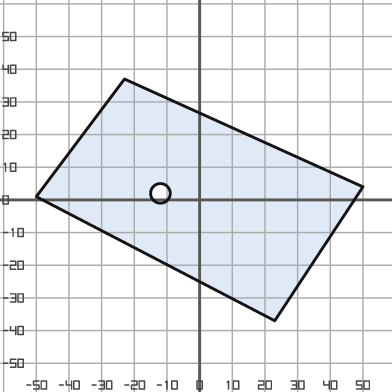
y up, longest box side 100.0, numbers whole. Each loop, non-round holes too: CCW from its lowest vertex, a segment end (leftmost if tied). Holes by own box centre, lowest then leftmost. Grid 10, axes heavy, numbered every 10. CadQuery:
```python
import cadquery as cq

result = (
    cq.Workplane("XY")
    .moveTo(23.0, -37.0)
    .lineTo(50.0, 4.0)
    .lineTo(-23.0, 37.0)
    .lineTo(-50.0, 1.0)
    .close()
    .moveTo(-12.0, 2.0)
    .circle(3.0)
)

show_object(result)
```